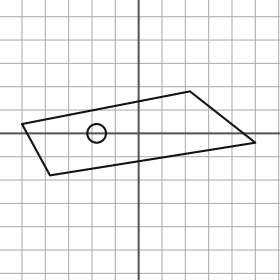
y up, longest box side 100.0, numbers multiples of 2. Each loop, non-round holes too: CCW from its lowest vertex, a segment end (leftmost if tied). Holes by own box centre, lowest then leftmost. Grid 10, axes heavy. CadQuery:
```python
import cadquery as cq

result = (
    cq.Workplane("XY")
    .moveTo(-38.0, -18.0)
    .lineTo(50.0, -4.0)
    .lineTo(22.0, 18.0)
    .lineTo(-50.0, 4.0)
    .close()
    .moveTo(-18.0, 0.0)
    .circle(4.0)
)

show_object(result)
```